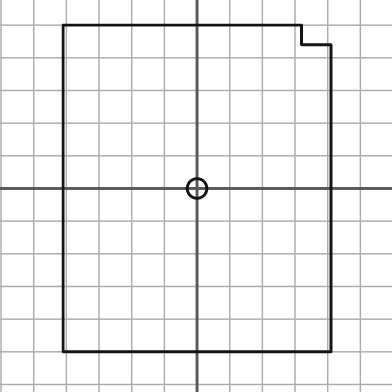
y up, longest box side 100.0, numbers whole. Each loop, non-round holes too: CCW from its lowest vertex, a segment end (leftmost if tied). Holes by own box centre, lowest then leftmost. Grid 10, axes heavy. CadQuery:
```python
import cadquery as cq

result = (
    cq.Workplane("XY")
    .moveTo(-41.0, -50.0)
    .lineTo(41.0, -50.0)
    .lineTo(41.0, 44.0)
    .lineTo(32.0, 44.0)
    .lineTo(32.0, 50.0)
    .lineTo(-41.0, 50.0)
    .close()
    .moveTo(0.0, 0.0)
    .circle(3.0)
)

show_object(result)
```